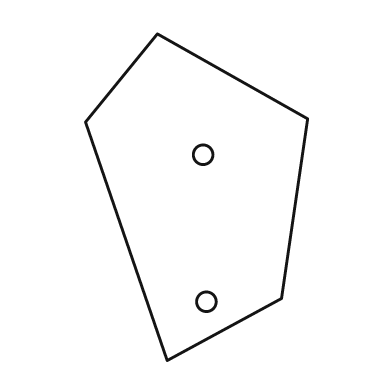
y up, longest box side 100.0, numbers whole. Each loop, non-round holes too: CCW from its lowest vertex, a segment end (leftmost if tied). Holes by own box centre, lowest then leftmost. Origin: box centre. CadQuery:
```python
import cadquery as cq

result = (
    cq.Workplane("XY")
    .moveTo(-9.0, -50.0)
    .lineTo(26.0, -31.0)
    .lineTo(34.0, 24.0)
    .lineTo(-12.0, 50.0)
    .lineTo(-34.0, 23.0)
    .close()
    .moveTo(3.0, -32.0)
    .circle(3.0)
    .moveTo(2.0, 13.0)
    .circle(3.0)
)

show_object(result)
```